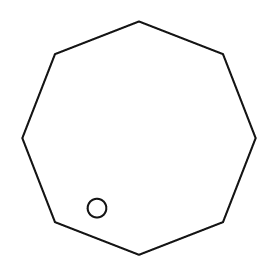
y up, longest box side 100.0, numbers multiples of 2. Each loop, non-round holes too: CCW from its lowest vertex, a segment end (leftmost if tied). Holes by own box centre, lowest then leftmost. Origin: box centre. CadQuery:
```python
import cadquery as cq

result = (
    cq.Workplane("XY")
    .moveTo(0.0, -50.0)
    .lineTo(36.0, -36.0)
    .lineTo(50.0, 0.0)
    .lineTo(36.0, 36.0)
    .lineTo(0.0, 50.0)
    .lineTo(-36.0, 36.0)
    .lineTo(-50.0, 0.0)
    .lineTo(-36.0, -36.0)
    .close()
    .moveTo(-18.0, -30.0)
    .circle(4.0)
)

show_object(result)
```